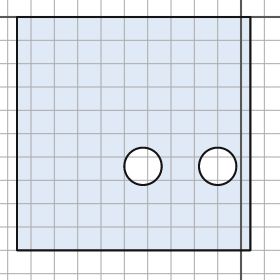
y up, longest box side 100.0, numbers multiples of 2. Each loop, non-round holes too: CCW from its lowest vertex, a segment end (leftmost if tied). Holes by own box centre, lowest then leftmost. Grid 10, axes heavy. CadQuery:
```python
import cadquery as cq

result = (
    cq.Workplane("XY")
    .moveTo(-96.0, -100.0)
    .lineTo(4.0, -100.0)
    .lineTo(4.0, 0.0)
    .lineTo(-96.0, 0.0)
    .close()
    .moveTo(-42.0, -64.0)
    .circle(8.0)
    .moveTo(-10.0, -64.0)
    .circle(8.0)
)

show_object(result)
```